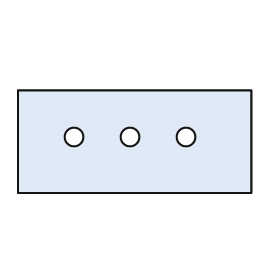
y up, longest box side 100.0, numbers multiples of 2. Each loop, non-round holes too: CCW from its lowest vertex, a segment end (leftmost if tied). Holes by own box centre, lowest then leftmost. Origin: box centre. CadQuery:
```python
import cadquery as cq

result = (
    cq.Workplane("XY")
    .moveTo(-50.0, -22.0)
    .lineTo(50.0, -22.0)
    .lineTo(50.0, 22.0)
    .lineTo(-50.0, 22.0)
    .close()
    .moveTo(-26.0, 2.0)
    .circle(4.0)
    .moveTo(-2.0, 2.0)
    .circle(4.0)
    .moveTo(22.0, 2.0)
    .circle(4.0)
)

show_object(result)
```